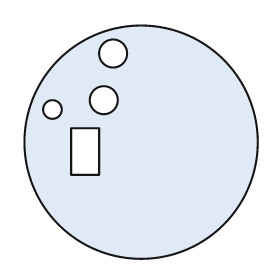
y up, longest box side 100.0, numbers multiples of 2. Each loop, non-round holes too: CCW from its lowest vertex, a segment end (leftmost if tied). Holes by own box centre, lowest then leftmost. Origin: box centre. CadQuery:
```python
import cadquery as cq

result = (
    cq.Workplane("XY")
    .moveTo(0.0, 0.0)
    .circle(50.0)
    .moveTo(-30.0, -14.0)
    .lineTo(-18.0, -14.0)
    .lineTo(-18.0, 6.0)
    .lineTo(-30.0, 6.0)
    .close()
    .moveTo(-38.0, 14.0)
    .circle(4.0)
    .moveTo(-16.0, 18.0)
    .circle(6.0)
    .moveTo(-12.0, 38.0)
    .circle(6.0)
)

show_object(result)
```